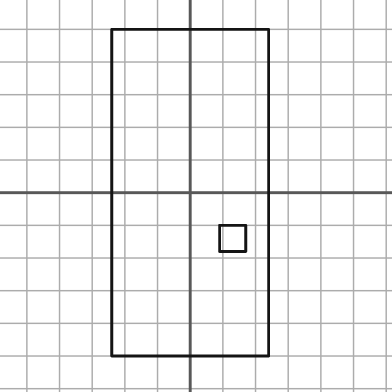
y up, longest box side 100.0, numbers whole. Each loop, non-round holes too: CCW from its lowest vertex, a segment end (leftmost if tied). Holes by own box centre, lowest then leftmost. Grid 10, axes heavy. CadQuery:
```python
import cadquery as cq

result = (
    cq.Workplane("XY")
    .moveTo(-24.0, -50.0)
    .lineTo(24.0, -50.0)
    .lineTo(24.0, 50.0)
    .lineTo(-24.0, 50.0)
    .close()
    .moveTo(9.0, -18.0)
    .lineTo(17.0, -18.0)
    .lineTo(17.0, -10.0)
    .lineTo(9.0, -10.0)
    .close()
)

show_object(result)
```